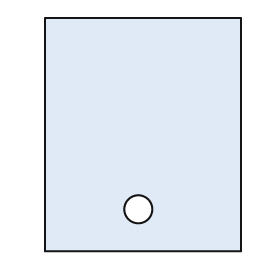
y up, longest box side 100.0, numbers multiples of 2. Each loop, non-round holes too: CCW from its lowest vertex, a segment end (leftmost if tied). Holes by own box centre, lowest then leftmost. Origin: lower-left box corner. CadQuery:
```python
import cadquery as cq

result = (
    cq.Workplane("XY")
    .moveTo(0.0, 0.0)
    .lineTo(84.0, 0.0)
    .lineTo(84.0, 100.0)
    .lineTo(0.0, 100.0)
    .close()
    .moveTo(40.0, 18.0)
    .circle(6.0)
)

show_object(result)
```